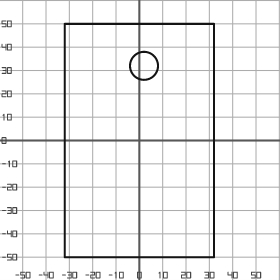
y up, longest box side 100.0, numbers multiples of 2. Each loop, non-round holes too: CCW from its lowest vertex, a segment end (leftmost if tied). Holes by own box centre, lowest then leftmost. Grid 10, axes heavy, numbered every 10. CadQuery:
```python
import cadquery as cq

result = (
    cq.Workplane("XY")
    .moveTo(-32.0, -50.0)
    .lineTo(32.0, -50.0)
    .lineTo(32.0, 50.0)
    .lineTo(-32.0, 50.0)
    .close()
    .moveTo(2.0, 32.0)
    .circle(6.0)
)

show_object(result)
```